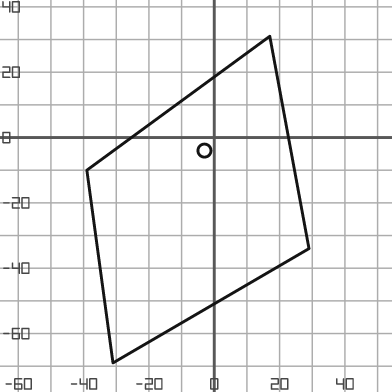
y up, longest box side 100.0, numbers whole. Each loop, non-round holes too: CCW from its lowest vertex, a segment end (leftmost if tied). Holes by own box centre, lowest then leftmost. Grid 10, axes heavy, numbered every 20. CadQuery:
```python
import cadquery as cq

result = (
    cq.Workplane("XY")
    .moveTo(-31.0, -69.0)
    .lineTo(29.0, -34.0)
    .lineTo(17.0, 31.0)
    .lineTo(-39.0, -10.0)
    .close()
    .moveTo(-3.0, -4.0)
    .circle(2.0)
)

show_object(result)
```